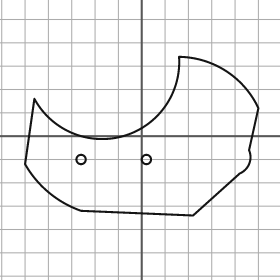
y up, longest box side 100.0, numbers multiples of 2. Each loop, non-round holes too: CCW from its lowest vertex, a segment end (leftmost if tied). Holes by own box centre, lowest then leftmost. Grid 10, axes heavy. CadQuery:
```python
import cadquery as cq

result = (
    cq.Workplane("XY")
    .moveTo(22.0, -34.0)
    .lineTo(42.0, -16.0)
    .threePointArc((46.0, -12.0), (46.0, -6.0))
    .lineTo(50.0, 12.0)
    .threePointArc((36.0, 28.0), (16.0, 34.0))
    .threePointArc((-8.0, 0.0), (-46.0, 16.0))
    .lineTo(-50.0, -12.0)
    .threePointArc((-40.0, -24.0), (-26.0, -32.0))
    .close()
    .moveTo(-26.0, -10.0)
    .circle(2.0)
    .moveTo(2.0, -10.0)
    .circle(2.0)
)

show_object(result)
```